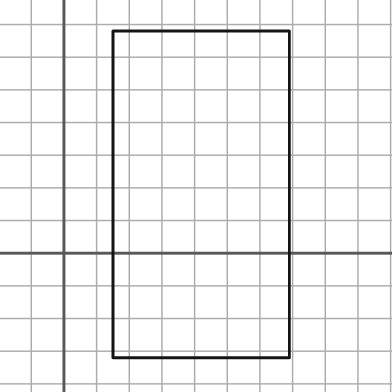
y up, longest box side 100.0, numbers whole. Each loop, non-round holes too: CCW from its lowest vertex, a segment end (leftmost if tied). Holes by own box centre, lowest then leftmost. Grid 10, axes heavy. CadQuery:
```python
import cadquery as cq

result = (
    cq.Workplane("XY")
    .moveTo(15.0, -32.0)
    .lineTo(69.0, -32.0)
    .lineTo(69.0, 68.0)
    .lineTo(15.0, 68.0)
    .close()
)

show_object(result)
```